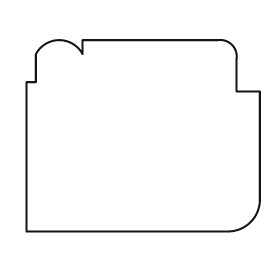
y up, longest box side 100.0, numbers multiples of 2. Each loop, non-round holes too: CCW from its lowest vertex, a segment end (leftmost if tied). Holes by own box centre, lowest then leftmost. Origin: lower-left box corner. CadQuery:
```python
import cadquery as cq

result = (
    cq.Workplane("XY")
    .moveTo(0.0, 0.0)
    .lineTo(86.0, 0.0)
    .threePointArc((96.0, 4.0), (100.0, 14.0))
    .lineTo(100.0, 60.0)
    .lineTo(90.0, 60.0)
    .lineTo(90.0, 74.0)
    .threePointArc((88.0, 80.0), (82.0, 82.0))
    .lineTo(24.0, 82.0)
    .lineTo(24.0, 76.0)
    .threePointArc((14.0, 82.0), (4.0, 76.0))
    .lineTo(4.0, 64.0)
    .lineTo(0.0, 64.0)
    .close()
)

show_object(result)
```